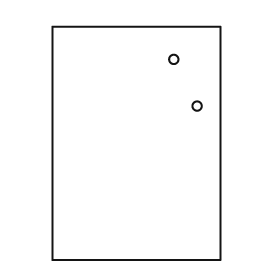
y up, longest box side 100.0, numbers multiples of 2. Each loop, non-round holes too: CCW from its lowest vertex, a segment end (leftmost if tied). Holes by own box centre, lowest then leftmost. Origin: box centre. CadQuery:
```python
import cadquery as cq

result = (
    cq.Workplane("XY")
    .moveTo(-36.0, -50.0)
    .lineTo(36.0, -50.0)
    .lineTo(36.0, 50.0)
    .lineTo(-36.0, 50.0)
    .close()
    .moveTo(26.0, 16.0)
    .circle(2.0)
    .moveTo(16.0, 36.0)
    .circle(2.0)
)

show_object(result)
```